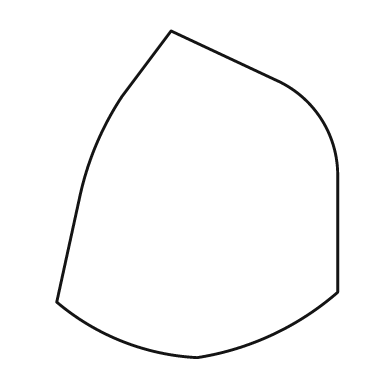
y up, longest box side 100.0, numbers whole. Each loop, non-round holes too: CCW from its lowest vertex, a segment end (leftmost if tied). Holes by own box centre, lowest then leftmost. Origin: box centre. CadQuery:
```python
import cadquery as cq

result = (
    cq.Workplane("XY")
    .moveTo(0.0, -50.0)
    .threePointArc((23.0, -43.0), (43.0, -30.0))
    .lineTo(43.0, 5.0)
    .threePointArc((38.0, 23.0), (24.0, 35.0))
    .lineTo(-8.0, 50.0)
    .lineTo(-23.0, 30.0)
    .threePointArc((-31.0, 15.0), (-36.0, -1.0))
    .lineTo(-43.0, -33.0)
    .threePointArc((-23.0, -45.0), (0.0, -50.0))
    .close()
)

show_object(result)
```